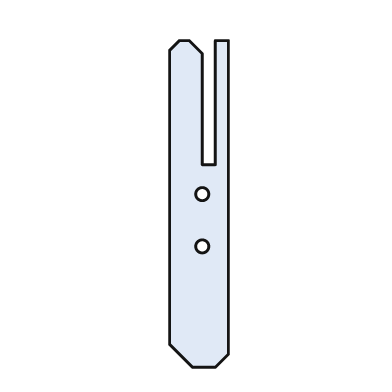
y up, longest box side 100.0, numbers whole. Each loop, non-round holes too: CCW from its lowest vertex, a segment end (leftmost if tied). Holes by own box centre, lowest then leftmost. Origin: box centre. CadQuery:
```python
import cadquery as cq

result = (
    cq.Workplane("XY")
    .moveTo(-2.0, -50.0)
    .lineTo(5.0, -50.0)
    .lineTo(9.0, -46.0)
    .lineTo(9.0, 50.0)
    .lineTo(5.0, 50.0)
    .lineTo(5.0, 12.0)
    .lineTo(1.0, 12.0)
    .lineTo(1.0, 46.0)
    .lineTo(-3.0, 50.0)
    .lineTo(-6.0, 50.0)
    .lineTo(-9.0, 47.0)
    .lineTo(-9.0, -43.0)
    .close()
    .moveTo(1.0, -13.0)
    .circle(2.0)
    .moveTo(1.0, 3.0)
    .circle(2.0)
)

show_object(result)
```